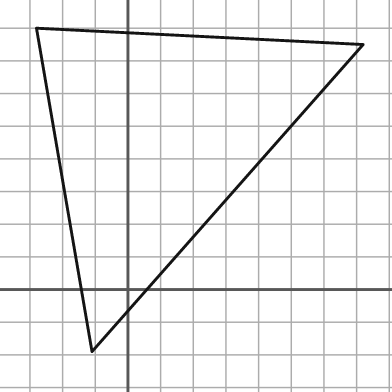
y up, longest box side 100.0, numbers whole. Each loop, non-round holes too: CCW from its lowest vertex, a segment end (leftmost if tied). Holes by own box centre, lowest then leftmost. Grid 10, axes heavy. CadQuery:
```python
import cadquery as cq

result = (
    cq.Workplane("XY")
    .moveTo(-11.0, -19.0)
    .lineTo(72.0, 75.0)
    .lineTo(-28.0, 80.0)
    .close()
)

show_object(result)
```